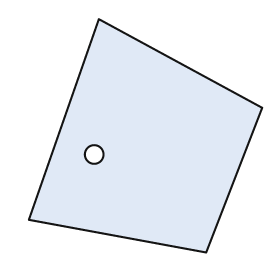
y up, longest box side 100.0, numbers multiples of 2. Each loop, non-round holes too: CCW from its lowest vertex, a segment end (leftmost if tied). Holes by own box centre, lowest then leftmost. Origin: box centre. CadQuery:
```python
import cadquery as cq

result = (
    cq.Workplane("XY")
    .moveTo(26.0, -50.0)
    .lineTo(50.0, 12.0)
    .lineTo(-20.0, 50.0)
    .lineTo(-50.0, -36.0)
    .close()
    .moveTo(-22.0, -8.0)
    .circle(4.0)
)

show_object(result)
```